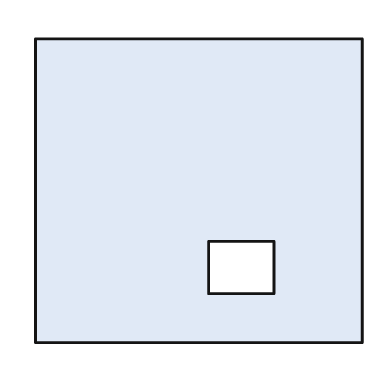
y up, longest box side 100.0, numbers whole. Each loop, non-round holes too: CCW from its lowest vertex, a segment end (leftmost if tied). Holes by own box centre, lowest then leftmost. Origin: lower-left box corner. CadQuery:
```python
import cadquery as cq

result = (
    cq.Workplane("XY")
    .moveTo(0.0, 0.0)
    .lineTo(100.0, 0.0)
    .lineTo(100.0, 93.0)
    .lineTo(0.0, 93.0)
    .close()
    .moveTo(53.0, 15.0)
    .lineTo(73.0, 15.0)
    .lineTo(73.0, 31.0)
    .lineTo(53.0, 31.0)
    .close()
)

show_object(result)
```